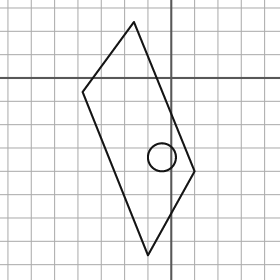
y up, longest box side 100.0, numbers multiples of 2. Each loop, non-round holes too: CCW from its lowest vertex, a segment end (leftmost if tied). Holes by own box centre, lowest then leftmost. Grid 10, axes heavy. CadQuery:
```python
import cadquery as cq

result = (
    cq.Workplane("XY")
    .moveTo(-10.0, -76.0)
    .lineTo(10.0, -40.0)
    .lineTo(-16.0, 24.0)
    .lineTo(-38.0, -6.0)
    .close()
    .moveTo(-4.0, -34.0)
    .circle(6.0)
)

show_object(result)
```